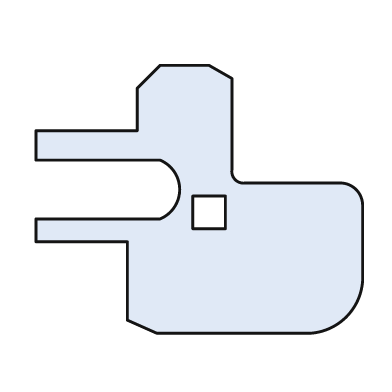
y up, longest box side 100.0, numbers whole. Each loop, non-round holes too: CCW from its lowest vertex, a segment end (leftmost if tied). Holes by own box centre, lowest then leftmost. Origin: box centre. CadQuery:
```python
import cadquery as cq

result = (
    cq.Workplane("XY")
    .moveTo(-13.0, -41.0)
    .lineTo(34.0, -41.0)
    .threePointArc((45.0, -36.0), (50.0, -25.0))
    .lineTo(50.0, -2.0)
    .threePointArc((48.0, 3.0), (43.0, 5.0))
    .lineTo(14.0, 5.0)
    .threePointArc((11.0, 6.0), (10.0, 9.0))
    .lineTo(10.0, 37.0)
    .lineTo(3.0, 41.0)
    .lineTo(-12.0, 41.0)
    .lineTo(-19.0, 34.0)
    .lineTo(-19.0, 21.0)
    .lineTo(-50.0, 21.0)
    .lineTo(-50.0, 12.0)
    .lineTo(-12.0, 12.0)
    .threePointArc((-6.0, 3.0), (-12.0, -6.0))
    .lineTo(-50.0, -6.0)
    .lineTo(-50.0, -13.0)
    .lineTo(-22.0, -13.0)
    .lineTo(-22.0, -37.0)
    .close()
    .moveTo(-2.0, -9.0)
    .lineTo(8.0, -9.0)
    .lineTo(8.0, 1.0)
    .lineTo(-2.0, 1.0)
    .close()
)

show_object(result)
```